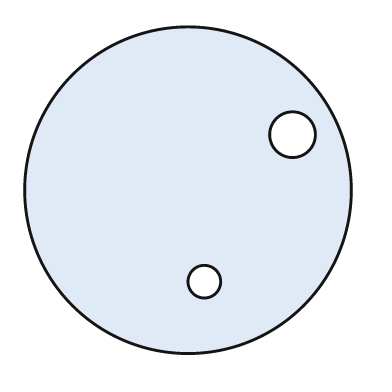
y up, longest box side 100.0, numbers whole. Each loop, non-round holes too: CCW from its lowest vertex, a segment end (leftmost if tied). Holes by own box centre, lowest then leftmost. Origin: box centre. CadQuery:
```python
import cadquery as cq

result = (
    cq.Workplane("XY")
    .moveTo(0.0, 0.0)
    .circle(50.0)
    .moveTo(5.0, -28.0)
    .circle(5.0)
    .moveTo(32.0, 17.0)
    .circle(7.0)
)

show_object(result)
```